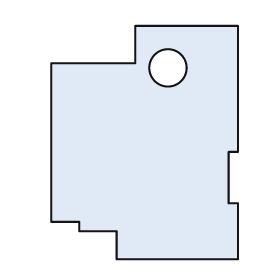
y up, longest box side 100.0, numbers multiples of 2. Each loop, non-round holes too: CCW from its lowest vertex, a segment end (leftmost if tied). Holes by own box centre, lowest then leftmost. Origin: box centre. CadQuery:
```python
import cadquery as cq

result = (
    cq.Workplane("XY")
    .moveTo(-12.0, -50.0)
    .lineTo(40.0, -50.0)
    .lineTo(40.0, -26.0)
    .lineTo(36.0, -26.0)
    .lineTo(36.0, -4.0)
    .lineTo(40.0, -4.0)
    .lineTo(40.0, 50.0)
    .lineTo(-4.0, 50.0)
    .lineTo(-4.0, 34.0)
    .lineTo(-40.0, 34.0)
    .lineTo(-40.0, -34.0)
    .lineTo(-28.0, -34.0)
    .lineTo(-28.0, -38.0)
    .lineTo(-12.0, -38.0)
    .close()
    .moveTo(10.0, 32.0)
    .circle(8.0)
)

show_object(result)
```